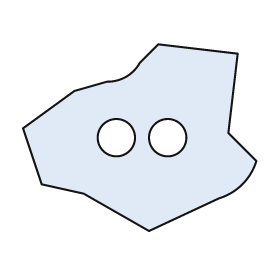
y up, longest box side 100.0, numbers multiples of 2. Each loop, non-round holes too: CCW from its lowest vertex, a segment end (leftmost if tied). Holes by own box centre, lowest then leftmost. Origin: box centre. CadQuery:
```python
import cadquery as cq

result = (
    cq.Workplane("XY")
    .moveTo(4.0, -40.0)
    .lineTo(34.0, -26.0)
    .threePointArc((44.0, -20.0), (50.0, -10.0))
    .lineTo(38.0, 2.0)
    .lineTo(42.0, 36.0)
    .lineTo(8.0, 40.0)
    .lineTo(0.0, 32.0)
    .threePointArc((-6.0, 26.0), (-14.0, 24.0))
    .lineTo(-28.0, 20.0)
    .lineTo(-50.0, 4.0)
    .lineTo(-42.0, -20.0)
    .lineTo(-24.0, -24.0)
    .close()
    .moveTo(-10.0, 0.0)
    .circle(8.0)
    .moveTo(12.0, 0.0)
    .circle(8.0)
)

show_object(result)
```